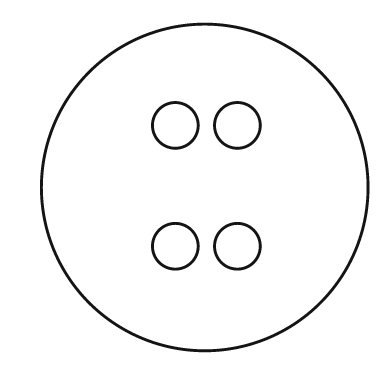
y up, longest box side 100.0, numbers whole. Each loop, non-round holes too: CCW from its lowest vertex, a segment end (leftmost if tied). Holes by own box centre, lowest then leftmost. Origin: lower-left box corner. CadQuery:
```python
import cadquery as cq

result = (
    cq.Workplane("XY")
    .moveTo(50.0, 50.0)
    .circle(50.0)
    .moveTo(41.0, 32.0)
    .circle(7.0)
    .moveTo(60.0, 32.0)
    .circle(7.0)
    .moveTo(41.0, 69.0)
    .circle(7.0)
    .moveTo(60.0, 69.0)
    .circle(7.0)
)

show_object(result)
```